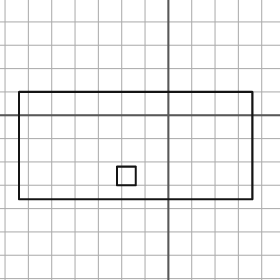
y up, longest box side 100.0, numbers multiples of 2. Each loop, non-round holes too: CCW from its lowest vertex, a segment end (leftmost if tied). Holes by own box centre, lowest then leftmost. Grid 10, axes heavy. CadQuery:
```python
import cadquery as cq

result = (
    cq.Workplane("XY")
    .moveTo(-64.0, -36.0)
    .lineTo(36.0, -36.0)
    .lineTo(36.0, 10.0)
    .lineTo(-64.0, 10.0)
    .close()
    .moveTo(-22.0, -30.0)
    .lineTo(-14.0, -30.0)
    .lineTo(-14.0, -22.0)
    .lineTo(-22.0, -22.0)
    .close()
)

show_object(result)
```